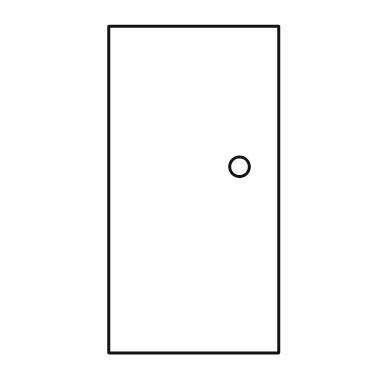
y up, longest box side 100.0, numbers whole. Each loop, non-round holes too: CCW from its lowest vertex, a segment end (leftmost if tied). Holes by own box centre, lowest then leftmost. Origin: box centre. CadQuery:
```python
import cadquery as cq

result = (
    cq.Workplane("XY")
    .moveTo(-26.0, -50.0)
    .lineTo(26.0, -50.0)
    .lineTo(26.0, 50.0)
    .lineTo(-26.0, 50.0)
    .close()
    .moveTo(14.0, 7.0)
    .circle(3.0)
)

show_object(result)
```